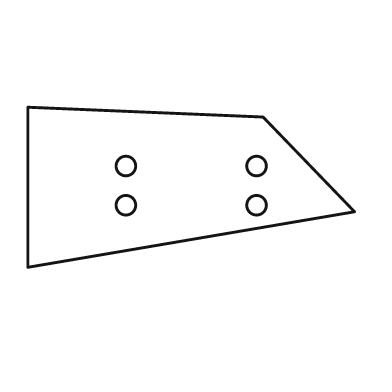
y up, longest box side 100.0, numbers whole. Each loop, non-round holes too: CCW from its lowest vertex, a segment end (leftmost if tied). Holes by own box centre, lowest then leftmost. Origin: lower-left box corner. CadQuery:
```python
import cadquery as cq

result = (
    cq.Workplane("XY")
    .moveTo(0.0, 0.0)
    .lineTo(100.0, 17.0)
    .lineTo(72.0, 46.0)
    .lineTo(0.0, 49.0)
    .close()
    .moveTo(30.0, 19.0)
    .circle(3.0)
    .moveTo(70.0, 19.0)
    .circle(3.0)
    .moveTo(30.0, 31.0)
    .circle(3.0)
    .moveTo(70.0, 31.0)
    .circle(3.0)
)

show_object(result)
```